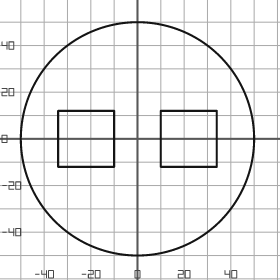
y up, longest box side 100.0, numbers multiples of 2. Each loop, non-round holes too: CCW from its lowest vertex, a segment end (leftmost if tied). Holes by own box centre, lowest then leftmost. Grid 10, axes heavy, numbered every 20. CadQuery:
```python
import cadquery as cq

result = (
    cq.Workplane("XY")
    .moveTo(0.0, 0.0)
    .circle(50.0)
    .moveTo(-34.0, -12.0)
    .lineTo(-10.0, -12.0)
    .lineTo(-10.0, 12.0)
    .lineTo(-34.0, 12.0)
    .close()
    .moveTo(10.0, -12.0)
    .lineTo(34.0, -12.0)
    .lineTo(34.0, 12.0)
    .lineTo(10.0, 12.0)
    .close()
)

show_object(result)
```